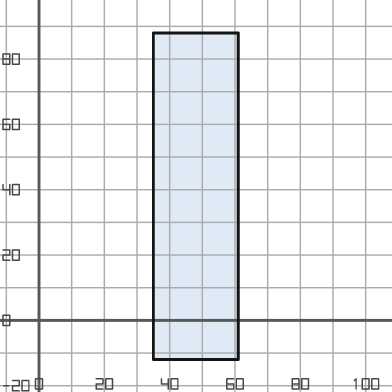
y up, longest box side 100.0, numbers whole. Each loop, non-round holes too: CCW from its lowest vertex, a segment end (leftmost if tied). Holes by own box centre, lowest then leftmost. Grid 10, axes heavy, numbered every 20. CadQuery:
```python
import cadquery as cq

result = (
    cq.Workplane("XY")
    .moveTo(35.0, -12.0)
    .lineTo(61.0, -12.0)
    .lineTo(61.0, 88.0)
    .lineTo(35.0, 88.0)
    .close()
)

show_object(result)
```